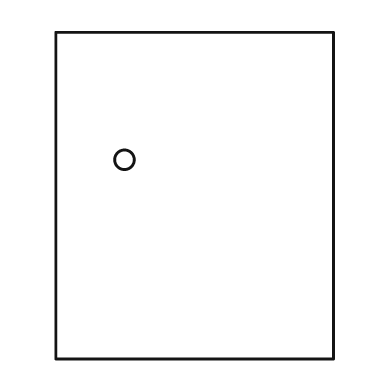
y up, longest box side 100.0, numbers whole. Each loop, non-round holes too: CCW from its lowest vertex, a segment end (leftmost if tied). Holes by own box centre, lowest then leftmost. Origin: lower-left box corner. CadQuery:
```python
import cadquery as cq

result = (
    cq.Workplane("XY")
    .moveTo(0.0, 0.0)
    .lineTo(85.0, 0.0)
    .lineTo(85.0, 100.0)
    .lineTo(0.0, 100.0)
    .close()
    .moveTo(21.0, 61.0)
    .circle(3.0)
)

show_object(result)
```